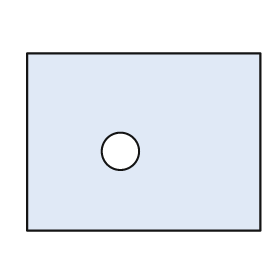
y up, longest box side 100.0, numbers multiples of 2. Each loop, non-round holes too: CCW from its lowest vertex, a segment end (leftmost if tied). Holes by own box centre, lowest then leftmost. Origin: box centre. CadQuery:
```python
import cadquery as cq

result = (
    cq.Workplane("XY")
    .moveTo(-50.0, -38.0)
    .lineTo(50.0, -38.0)
    .lineTo(50.0, 38.0)
    .lineTo(-50.0, 38.0)
    .close()
    .moveTo(-10.0, -4.0)
    .circle(8.0)
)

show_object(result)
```